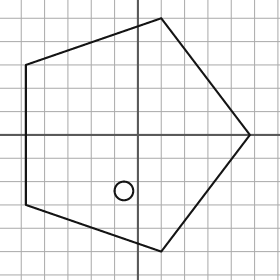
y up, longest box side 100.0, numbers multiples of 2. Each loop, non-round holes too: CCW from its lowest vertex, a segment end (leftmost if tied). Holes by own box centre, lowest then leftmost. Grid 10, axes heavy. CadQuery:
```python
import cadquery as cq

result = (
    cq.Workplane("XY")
    .moveTo(10.0, -50.0)
    .lineTo(48.0, 0.0)
    .lineTo(10.0, 50.0)
    .lineTo(-48.0, 30.0)
    .lineTo(-48.0, -30.0)
    .close()
    .moveTo(-6.0, -24.0)
    .circle(4.0)
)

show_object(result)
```